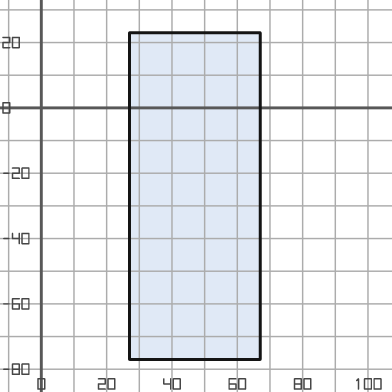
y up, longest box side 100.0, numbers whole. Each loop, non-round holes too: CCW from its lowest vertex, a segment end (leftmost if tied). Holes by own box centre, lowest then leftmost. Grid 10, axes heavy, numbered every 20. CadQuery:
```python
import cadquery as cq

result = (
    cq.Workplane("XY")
    .moveTo(27.0, -77.0)
    .lineTo(67.0, -77.0)
    .lineTo(67.0, 23.0)
    .lineTo(27.0, 23.0)
    .close()
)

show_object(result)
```